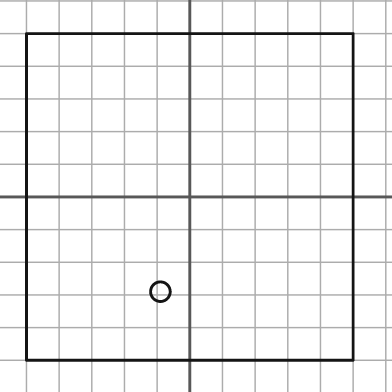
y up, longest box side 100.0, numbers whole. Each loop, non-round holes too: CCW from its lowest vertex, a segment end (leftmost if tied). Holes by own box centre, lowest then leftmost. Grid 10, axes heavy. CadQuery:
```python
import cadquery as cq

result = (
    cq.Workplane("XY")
    .moveTo(-50.0, -50.0)
    .lineTo(50.0, -50.0)
    .lineTo(50.0, 50.0)
    .lineTo(-50.0, 50.0)
    .close()
    .moveTo(-9.0, -29.0)
    .circle(3.0)
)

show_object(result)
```